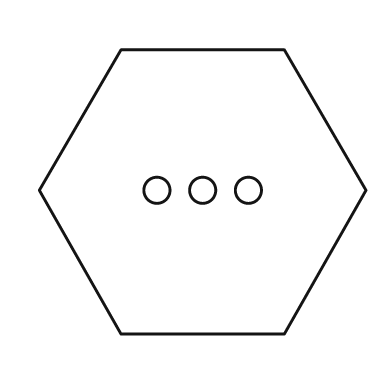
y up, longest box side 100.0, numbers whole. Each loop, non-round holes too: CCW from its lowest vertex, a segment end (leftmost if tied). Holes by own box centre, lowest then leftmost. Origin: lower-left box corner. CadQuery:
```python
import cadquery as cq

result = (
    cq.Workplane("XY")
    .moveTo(25.0, 0.0)
    .lineTo(75.0, 0.0)
    .lineTo(100.0, 44.0)
    .lineTo(75.0, 87.0)
    .lineTo(25.0, 87.0)
    .lineTo(0.0, 44.0)
    .close()
    .moveTo(36.0, 44.0)
    .circle(4.0)
    .moveTo(50.0, 44.0)
    .circle(4.0)
    .moveTo(64.0, 44.0)
    .circle(4.0)
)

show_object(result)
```